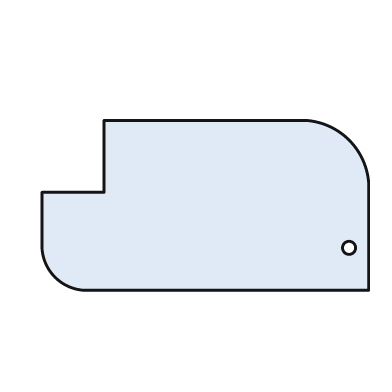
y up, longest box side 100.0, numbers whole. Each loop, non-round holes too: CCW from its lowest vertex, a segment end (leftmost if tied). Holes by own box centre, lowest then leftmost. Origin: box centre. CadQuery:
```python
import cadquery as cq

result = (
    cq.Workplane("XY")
    .moveTo(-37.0, -26.0)
    .lineTo(50.0, -26.0)
    .lineTo(50.0, 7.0)
    .threePointArc((44.0, 20.0), (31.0, 26.0))
    .lineTo(-31.0, 26.0)
    .lineTo(-31.0, 4.0)
    .lineTo(-50.0, 4.0)
    .lineTo(-50.0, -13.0)
    .threePointArc((-46.0, -22.0), (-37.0, -26.0))
    .close()
    .moveTo(44.0, -13.0)
    .circle(2.0)
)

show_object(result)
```